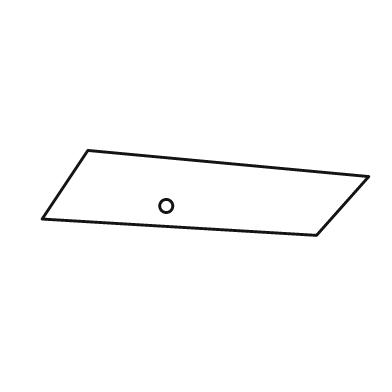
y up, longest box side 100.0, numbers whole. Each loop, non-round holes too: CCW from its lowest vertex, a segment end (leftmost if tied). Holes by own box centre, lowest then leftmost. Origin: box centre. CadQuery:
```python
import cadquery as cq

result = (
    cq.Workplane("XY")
    .moveTo(34.0, -13.0)
    .lineTo(50.0, 5.0)
    .lineTo(-36.0, 13.0)
    .lineTo(-50.0, -8.0)
    .close()
    .moveTo(-12.0, -4.0)
    .circle(2.0)
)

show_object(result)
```